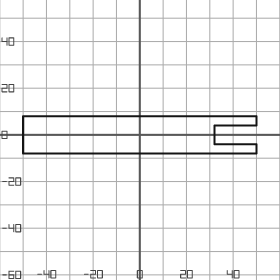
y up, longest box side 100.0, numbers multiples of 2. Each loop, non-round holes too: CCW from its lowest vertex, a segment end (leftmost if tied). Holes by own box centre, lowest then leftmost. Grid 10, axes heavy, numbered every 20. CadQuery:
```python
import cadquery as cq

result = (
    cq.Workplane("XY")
    .moveTo(-50.0, -8.0)
    .lineTo(50.0, -8.0)
    .lineTo(50.0, -4.0)
    .lineTo(32.0, -4.0)
    .lineTo(32.0, 4.0)
    .lineTo(50.0, 4.0)
    .lineTo(50.0, 8.0)
    .lineTo(-50.0, 8.0)
    .close()
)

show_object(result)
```